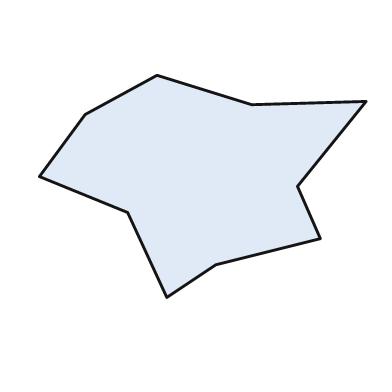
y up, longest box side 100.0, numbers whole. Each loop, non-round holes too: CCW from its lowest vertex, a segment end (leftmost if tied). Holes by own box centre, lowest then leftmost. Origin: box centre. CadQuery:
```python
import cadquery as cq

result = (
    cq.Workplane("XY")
    .moveTo(-11.0, -34.0)
    .lineTo(4.0, -24.0)
    .lineTo(36.0, -16.0)
    .lineTo(29.0, 0.0)
    .lineTo(50.0, 26.0)
    .lineTo(15.0, 25.0)
    .lineTo(-14.0, 34.0)
    .lineTo(-36.0, 22.0)
    .lineTo(-50.0, 3.0)
    .lineTo(-23.0, -8.0)
    .close()
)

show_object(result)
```